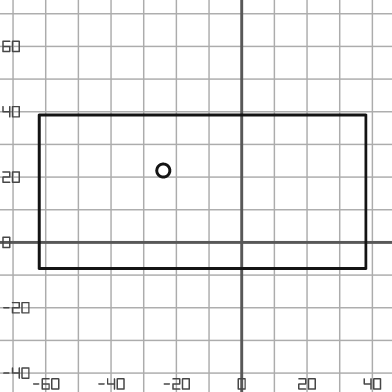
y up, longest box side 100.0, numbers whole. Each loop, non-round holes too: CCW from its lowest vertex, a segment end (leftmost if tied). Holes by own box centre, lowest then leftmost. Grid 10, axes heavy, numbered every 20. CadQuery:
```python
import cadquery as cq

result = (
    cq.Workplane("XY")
    .moveTo(-62.0, -8.0)
    .lineTo(38.0, -8.0)
    .lineTo(38.0, 39.0)
    .lineTo(-62.0, 39.0)
    .close()
    .moveTo(-24.0, 22.0)
    .circle(2.0)
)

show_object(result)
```